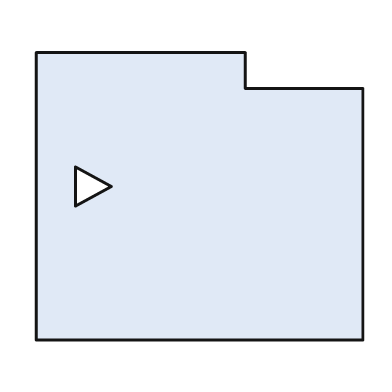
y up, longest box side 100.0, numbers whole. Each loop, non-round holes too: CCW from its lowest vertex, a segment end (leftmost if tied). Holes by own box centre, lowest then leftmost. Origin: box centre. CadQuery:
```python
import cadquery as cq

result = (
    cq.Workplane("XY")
    .moveTo(-50.0, -44.0)
    .lineTo(50.0, -44.0)
    .lineTo(50.0, 33.0)
    .lineTo(14.0, 33.0)
    .lineTo(14.0, 44.0)
    .lineTo(-50.0, 44.0)
    .close()
    .moveTo(-38.0, -3.0)
    .lineTo(-27.0, 3.0)
    .lineTo(-38.0, 9.0)
    .close()
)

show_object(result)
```